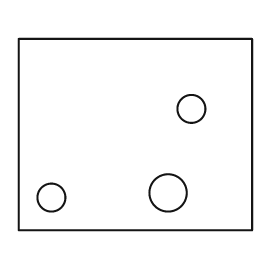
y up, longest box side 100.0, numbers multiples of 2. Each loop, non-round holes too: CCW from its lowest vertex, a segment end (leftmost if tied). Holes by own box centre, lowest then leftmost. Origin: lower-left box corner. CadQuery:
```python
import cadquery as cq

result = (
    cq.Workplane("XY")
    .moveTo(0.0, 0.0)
    .lineTo(100.0, 0.0)
    .lineTo(100.0, 82.0)
    .lineTo(0.0, 82.0)
    .close()
    .moveTo(14.0, 14.0)
    .circle(6.0)
    .moveTo(64.0, 16.0)
    .circle(8.0)
    .moveTo(74.0, 52.0)
    .circle(6.0)
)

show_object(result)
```